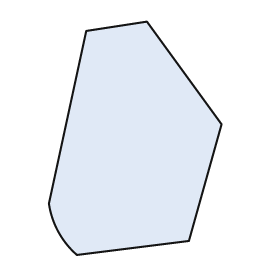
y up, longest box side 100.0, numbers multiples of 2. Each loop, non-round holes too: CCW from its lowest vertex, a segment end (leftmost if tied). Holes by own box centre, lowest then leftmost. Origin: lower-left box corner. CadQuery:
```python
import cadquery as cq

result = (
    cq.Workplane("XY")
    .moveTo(12.0, 0.0)
    .lineTo(60.0, 6.0)
    .lineTo(74.0, 56.0)
    .lineTo(42.0, 100.0)
    .lineTo(16.0, 96.0)
    .lineTo(0.0, 22.0)
    .threePointArc((4.0, 10.0), (12.0, 0.0))
    .close()
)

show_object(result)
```